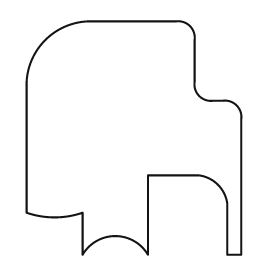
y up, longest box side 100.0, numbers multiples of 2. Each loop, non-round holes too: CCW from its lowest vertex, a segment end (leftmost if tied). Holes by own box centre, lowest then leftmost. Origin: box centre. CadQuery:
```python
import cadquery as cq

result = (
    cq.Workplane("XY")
    .moveTo(-22.0, -50.0)
    .threePointArc((-8.0, -42.0), (6.0, -50.0))
    .lineTo(6.0, -16.0)
    .lineTo(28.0, -16.0)
    .threePointArc((36.0, -20.0), (40.0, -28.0))
    .lineTo(40.0, -50.0)
    .lineTo(46.0, -50.0)
    .lineTo(46.0, 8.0)
    .threePointArc((44.0, 14.0), (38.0, 16.0))
    .lineTo(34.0, 16.0)
    .threePointArc((28.0, 18.0), (26.0, 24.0))
    .lineTo(26.0, 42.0)
    .threePointArc((24.0, 48.0), (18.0, 50.0))
    .lineTo(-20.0, 50.0)
    .threePointArc((-38.0, 42.0), (-46.0, 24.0))
    .lineTo(-46.0, -32.0)
    .threePointArc((-34.0, -34.0), (-22.0, -32.0))
    .close()
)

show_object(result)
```